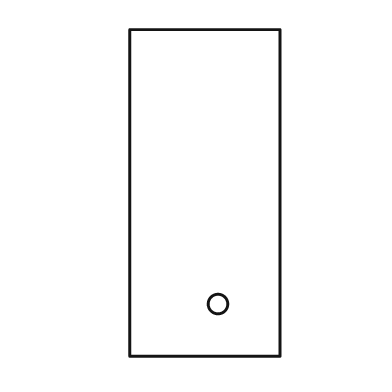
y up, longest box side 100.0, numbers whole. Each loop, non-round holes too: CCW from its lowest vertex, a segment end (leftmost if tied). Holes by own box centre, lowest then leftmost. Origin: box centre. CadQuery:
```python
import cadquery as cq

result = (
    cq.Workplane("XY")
    .moveTo(-23.0, -50.0)
    .lineTo(23.0, -50.0)
    .lineTo(23.0, 50.0)
    .lineTo(-23.0, 50.0)
    .close()
    .moveTo(4.0, -34.0)
    .circle(3.0)
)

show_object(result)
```